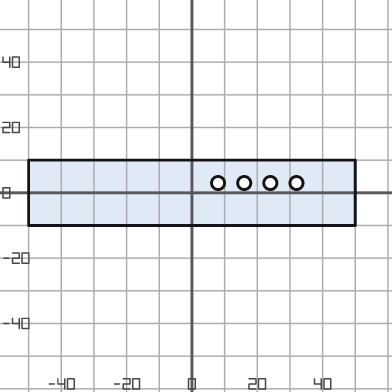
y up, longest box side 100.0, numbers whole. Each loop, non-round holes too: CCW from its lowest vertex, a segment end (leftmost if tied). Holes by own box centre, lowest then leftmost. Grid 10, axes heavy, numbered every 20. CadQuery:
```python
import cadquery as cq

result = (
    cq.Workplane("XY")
    .moveTo(-50.0, -10.0)
    .lineTo(50.0, -10.0)
    .lineTo(50.0, 10.0)
    .lineTo(-50.0, 10.0)
    .close()
    .moveTo(8.0, 3.0)
    .circle(2.0)
    .moveTo(16.0, 3.0)
    .circle(2.0)
    .moveTo(24.0, 3.0)
    .circle(2.0)
    .moveTo(32.0, 3.0)
    .circle(2.0)
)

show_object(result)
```